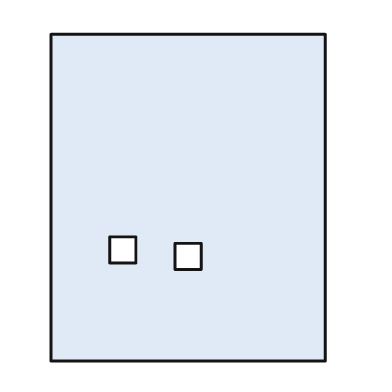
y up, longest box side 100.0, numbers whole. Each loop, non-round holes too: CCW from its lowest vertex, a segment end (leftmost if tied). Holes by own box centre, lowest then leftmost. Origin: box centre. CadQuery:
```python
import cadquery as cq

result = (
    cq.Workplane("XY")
    .moveTo(-42.0, -50.0)
    .lineTo(42.0, -50.0)
    .lineTo(42.0, 50.0)
    .lineTo(-42.0, 50.0)
    .close()
    .moveTo(-4.0, -22.0)
    .lineTo(4.0, -22.0)
    .lineTo(4.0, -14.0)
    .lineTo(-4.0, -14.0)
    .close()
    .moveTo(-24.0, -20.0)
    .lineTo(-16.0, -20.0)
    .lineTo(-16.0, -12.0)
    .lineTo(-24.0, -12.0)
    .close()
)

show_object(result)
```